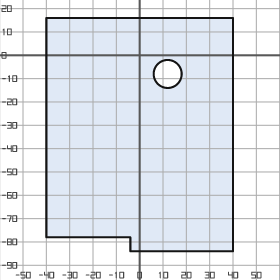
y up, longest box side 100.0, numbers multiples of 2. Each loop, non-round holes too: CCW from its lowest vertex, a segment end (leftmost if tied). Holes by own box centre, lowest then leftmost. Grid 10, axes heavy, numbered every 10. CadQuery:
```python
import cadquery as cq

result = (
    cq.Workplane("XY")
    .moveTo(-4.0, -84.0)
    .lineTo(40.0, -84.0)
    .lineTo(40.0, 16.0)
    .lineTo(-40.0, 16.0)
    .lineTo(-40.0, -78.0)
    .lineTo(-4.0, -78.0)
    .close()
    .moveTo(12.0, -8.0)
    .circle(6.0)
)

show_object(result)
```